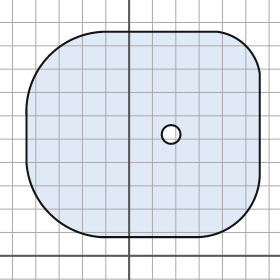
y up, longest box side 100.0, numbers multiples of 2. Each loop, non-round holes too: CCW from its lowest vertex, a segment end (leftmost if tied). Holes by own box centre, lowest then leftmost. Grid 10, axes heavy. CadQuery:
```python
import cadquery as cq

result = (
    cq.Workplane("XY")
    .moveTo(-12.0, 8.0)
    .lineTo(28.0, 8.0)
    .threePointArc((48.0, 16.0), (56.0, 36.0))
    .lineTo(56.0, 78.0)
    .threePointArc((50.0, 90.0), (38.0, 96.0))
    .lineTo(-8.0, 96.0)
    .threePointArc((-34.0, 86.0), (-44.0, 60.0))
    .lineTo(-44.0, 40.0)
    .threePointArc((-34.0, 18.0), (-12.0, 8.0))
    .close()
    .moveTo(18.0, 52.0)
    .circle(4.0)
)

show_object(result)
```